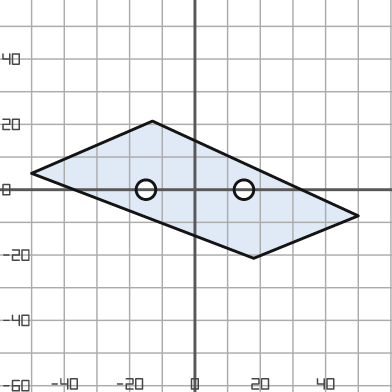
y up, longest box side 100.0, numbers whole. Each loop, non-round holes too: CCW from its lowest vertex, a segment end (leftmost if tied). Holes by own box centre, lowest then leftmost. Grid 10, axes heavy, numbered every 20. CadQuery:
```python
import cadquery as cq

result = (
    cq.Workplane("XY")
    .moveTo(18.0, -21.0)
    .lineTo(50.0, -8.0)
    .lineTo(-13.0, 21.0)
    .lineTo(-50.0, 5.0)
    .close()
    .moveTo(-15.0, 0.0)
    .circle(3.0)
    .moveTo(15.0, 0.0)
    .circle(3.0)
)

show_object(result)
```